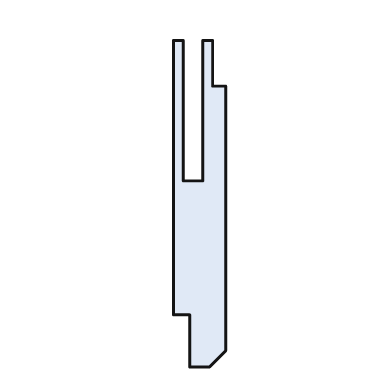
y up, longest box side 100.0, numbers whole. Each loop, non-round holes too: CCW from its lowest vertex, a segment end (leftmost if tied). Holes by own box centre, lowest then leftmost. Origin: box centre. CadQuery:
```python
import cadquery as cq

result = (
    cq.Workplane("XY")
    .moveTo(-3.0, -50.0)
    .lineTo(3.0, -50.0)
    .lineTo(8.0, -45.0)
    .lineTo(8.0, 36.0)
    .lineTo(4.0, 36.0)
    .lineTo(4.0, 50.0)
    .lineTo(1.0, 50.0)
    .lineTo(1.0, 7.0)
    .lineTo(-5.0, 7.0)
    .lineTo(-5.0, 50.0)
    .lineTo(-8.0, 50.0)
    .lineTo(-8.0, -34.0)
    .lineTo(-3.0, -34.0)
    .close()
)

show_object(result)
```